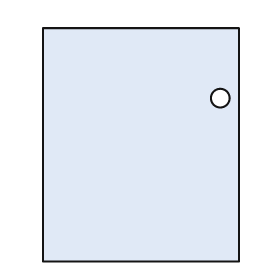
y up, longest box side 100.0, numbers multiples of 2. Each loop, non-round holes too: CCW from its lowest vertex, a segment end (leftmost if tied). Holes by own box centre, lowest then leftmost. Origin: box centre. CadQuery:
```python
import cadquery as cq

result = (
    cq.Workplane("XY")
    .moveTo(-42.0, -50.0)
    .lineTo(42.0, -50.0)
    .lineTo(42.0, 50.0)
    .lineTo(-42.0, 50.0)
    .close()
    .moveTo(34.0, 20.0)
    .circle(4.0)
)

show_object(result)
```